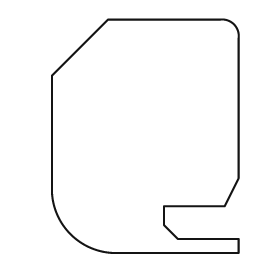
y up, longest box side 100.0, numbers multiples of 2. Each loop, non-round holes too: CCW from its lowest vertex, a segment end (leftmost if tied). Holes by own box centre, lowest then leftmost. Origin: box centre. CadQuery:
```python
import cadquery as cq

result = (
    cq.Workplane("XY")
    .moveTo(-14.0, -50.0)
    .lineTo(40.0, -50.0)
    .lineTo(40.0, -44.0)
    .lineTo(14.0, -44.0)
    .lineTo(8.0, -38.0)
    .lineTo(8.0, -30.0)
    .lineTo(34.0, -30.0)
    .lineTo(40.0, -18.0)
    .lineTo(40.0, 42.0)
    .threePointArc((38.0, 48.0), (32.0, 50.0))
    .lineTo(-16.0, 50.0)
    .lineTo(-40.0, 26.0)
    .lineTo(-40.0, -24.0)
    .threePointArc((-32.0, -42.0), (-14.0, -50.0))
    .close()
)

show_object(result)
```